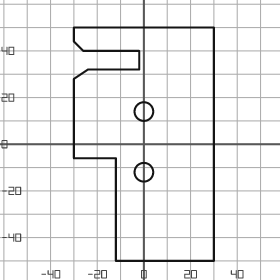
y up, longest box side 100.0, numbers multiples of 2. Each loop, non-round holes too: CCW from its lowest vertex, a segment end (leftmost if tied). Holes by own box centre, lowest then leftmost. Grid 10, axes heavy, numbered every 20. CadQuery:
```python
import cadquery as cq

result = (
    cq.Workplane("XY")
    .moveTo(-12.0, -50.0)
    .lineTo(30.0, -50.0)
    .lineTo(30.0, 50.0)
    .lineTo(-30.0, 50.0)
    .lineTo(-30.0, 44.0)
    .lineTo(-26.0, 40.0)
    .lineTo(-2.0, 40.0)
    .lineTo(-2.0, 32.0)
    .lineTo(-24.0, 32.0)
    .lineTo(-30.0, 28.0)
    .lineTo(-30.0, -6.0)
    .lineTo(-12.0, -6.0)
    .close()
    .moveTo(0.0, -12.0)
    .circle(4.0)
    .moveTo(0.0, 14.0)
    .circle(4.0)
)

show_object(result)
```